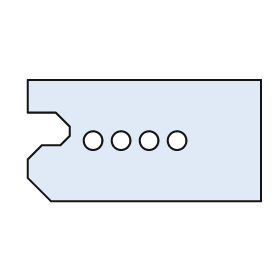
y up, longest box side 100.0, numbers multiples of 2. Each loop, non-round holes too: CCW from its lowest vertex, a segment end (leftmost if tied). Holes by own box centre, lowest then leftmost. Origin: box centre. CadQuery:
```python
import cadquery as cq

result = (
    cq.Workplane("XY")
    .moveTo(-40.0, -26.0)
    .lineTo(50.0, -26.0)
    .lineTo(50.0, 26.0)
    .lineTo(-50.0, 26.0)
    .lineTo(-50.0, 12.0)
    .lineTo(-38.0, 12.0)
    .lineTo(-32.0, 6.0)
    .lineTo(-32.0, 2.0)
    .lineTo(-36.0, -2.0)
    .lineTo(-44.0, -2.0)
    .lineTo(-50.0, -8.0)
    .lineTo(-50.0, -16.0)
    .close()
    .moveTo(-22.0, 0.0)
    .circle(4.0)
    .moveTo(-10.0, 0.0)
    .circle(4.0)
    .moveTo(2.0, 0.0)
    .circle(4.0)
    .moveTo(14.0, 0.0)
    .circle(4.0)
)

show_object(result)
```